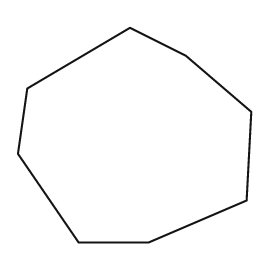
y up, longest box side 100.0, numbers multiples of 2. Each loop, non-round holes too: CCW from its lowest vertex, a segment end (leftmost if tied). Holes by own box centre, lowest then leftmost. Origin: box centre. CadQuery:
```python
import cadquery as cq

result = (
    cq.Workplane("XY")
    .moveTo(-24.0, -46.0)
    .lineTo(6.0, -46.0)
    .lineTo(48.0, -28.0)
    .lineTo(50.0, 10.0)
    .lineTo(22.0, 34.0)
    .lineTo(-2.0, 46.0)
    .lineTo(-46.0, 20.0)
    .lineTo(-50.0, -8.0)
    .close()
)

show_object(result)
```